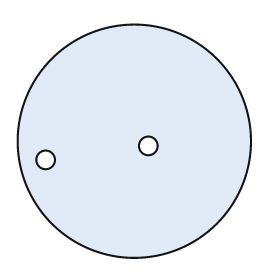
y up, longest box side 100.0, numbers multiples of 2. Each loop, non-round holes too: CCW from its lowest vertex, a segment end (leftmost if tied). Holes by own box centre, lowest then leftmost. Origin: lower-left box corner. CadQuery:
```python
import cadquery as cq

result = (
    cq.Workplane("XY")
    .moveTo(50.0, 50.0)
    .circle(50.0)
    .moveTo(12.0, 42.0)
    .circle(4.0)
    .moveTo(56.0, 48.0)
    .circle(4.0)
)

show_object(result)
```